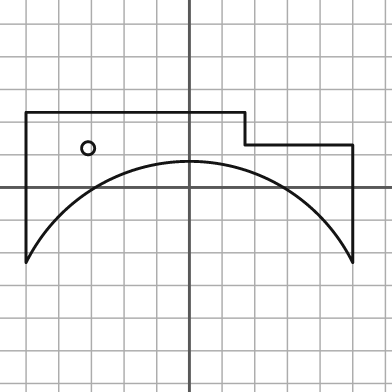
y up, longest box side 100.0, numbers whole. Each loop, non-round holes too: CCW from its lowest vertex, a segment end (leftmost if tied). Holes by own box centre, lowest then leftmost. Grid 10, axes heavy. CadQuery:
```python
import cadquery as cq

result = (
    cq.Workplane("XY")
    .moveTo(-50.0, -23.0)
    .threePointArc((0.0, 8.0), (50.0, -23.0))
    .lineTo(50.0, 13.0)
    .lineTo(17.0, 13.0)
    .lineTo(17.0, 23.0)
    .lineTo(-50.0, 23.0)
    .close()
    .moveTo(-31.0, 12.0)
    .circle(2.0)
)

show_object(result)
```